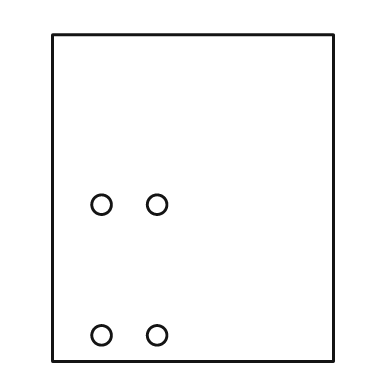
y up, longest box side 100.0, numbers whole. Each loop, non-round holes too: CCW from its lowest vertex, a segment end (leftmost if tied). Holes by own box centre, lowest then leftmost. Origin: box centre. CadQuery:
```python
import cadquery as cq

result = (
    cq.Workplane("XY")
    .moveTo(-43.0, -50.0)
    .lineTo(43.0, -50.0)
    .lineTo(43.0, 50.0)
    .lineTo(-43.0, 50.0)
    .close()
    .moveTo(-28.0, -42.0)
    .circle(3.0)
    .moveTo(-11.0, -42.0)
    .circle(3.0)
    .moveTo(-28.0, -2.0)
    .circle(3.0)
    .moveTo(-11.0, -2.0)
    .circle(3.0)
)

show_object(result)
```